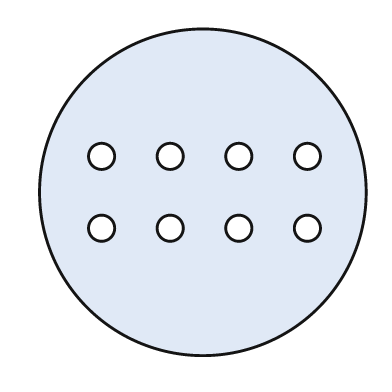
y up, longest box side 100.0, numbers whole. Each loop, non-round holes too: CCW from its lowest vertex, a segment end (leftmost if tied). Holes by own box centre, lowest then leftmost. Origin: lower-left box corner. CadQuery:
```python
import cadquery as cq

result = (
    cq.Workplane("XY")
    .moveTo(50.0, 50.0)
    .circle(50.0)
    .moveTo(19.0, 39.0)
    .circle(4.0)
    .moveTo(40.0, 39.0)
    .circle(4.0)
    .moveTo(61.0, 39.0)
    .circle(4.0)
    .moveTo(82.0, 39.0)
    .circle(4.0)
    .moveTo(19.0, 61.0)
    .circle(4.0)
    .moveTo(40.0, 61.0)
    .circle(4.0)
    .moveTo(61.0, 61.0)
    .circle(4.0)
    .moveTo(82.0, 61.0)
    .circle(4.0)
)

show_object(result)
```